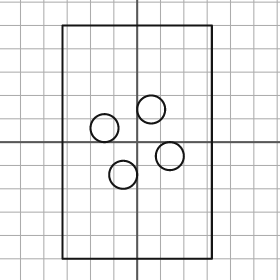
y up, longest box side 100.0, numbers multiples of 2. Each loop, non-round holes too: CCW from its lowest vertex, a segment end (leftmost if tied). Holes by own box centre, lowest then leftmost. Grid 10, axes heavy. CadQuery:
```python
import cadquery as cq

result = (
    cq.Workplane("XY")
    .moveTo(-32.0, -50.0)
    .lineTo(32.0, -50.0)
    .lineTo(32.0, 50.0)
    .lineTo(-32.0, 50.0)
    .close()
    .moveTo(-6.0, -14.0)
    .circle(6.0)
    .moveTo(14.0, -6.0)
    .circle(6.0)
    .moveTo(-14.0, 6.0)
    .circle(6.0)
    .moveTo(6.0, 14.0)
    .circle(6.0)
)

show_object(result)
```